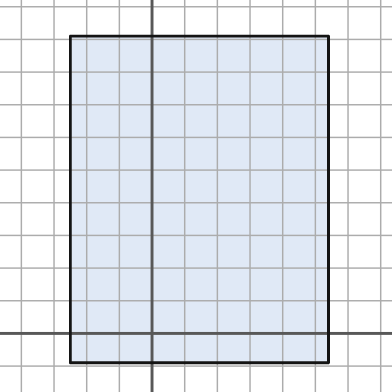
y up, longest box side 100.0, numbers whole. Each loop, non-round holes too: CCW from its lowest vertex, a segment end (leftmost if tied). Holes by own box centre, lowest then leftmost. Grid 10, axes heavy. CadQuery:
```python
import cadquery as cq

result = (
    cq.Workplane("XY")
    .moveTo(-25.0, -9.0)
    .lineTo(54.0, -9.0)
    .lineTo(54.0, 91.0)
    .lineTo(-25.0, 91.0)
    .close()
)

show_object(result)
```